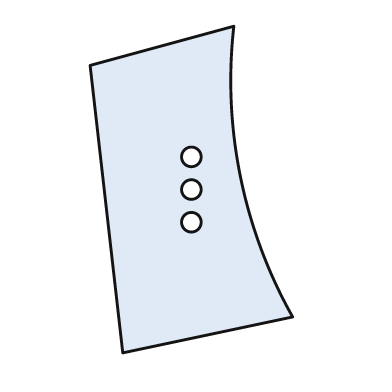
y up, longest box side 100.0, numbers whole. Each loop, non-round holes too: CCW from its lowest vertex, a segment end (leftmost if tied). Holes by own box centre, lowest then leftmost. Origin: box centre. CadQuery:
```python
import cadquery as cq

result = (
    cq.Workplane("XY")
    .moveTo(-21.0, -50.0)
    .lineTo(31.0, -39.0)
    .threePointArc((15.0, 4.0), (13.0, 50.0))
    .lineTo(-31.0, 38.0)
    .close()
    .moveTo(0.0, -10.0)
    .circle(3.0)
    .moveTo(0.0, 0.0)
    .circle(3.0)
    .moveTo(0.0, 10.0)
    .circle(3.0)
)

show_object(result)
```